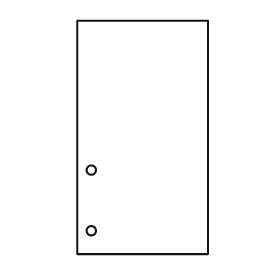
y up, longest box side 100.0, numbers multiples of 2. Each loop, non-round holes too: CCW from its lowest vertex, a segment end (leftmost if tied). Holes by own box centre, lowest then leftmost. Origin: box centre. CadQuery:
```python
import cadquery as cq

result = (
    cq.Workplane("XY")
    .moveTo(-28.0, -50.0)
    .lineTo(28.0, -50.0)
    .lineTo(28.0, 50.0)
    .lineTo(-28.0, 50.0)
    .close()
    .moveTo(-22.0, -40.0)
    .circle(2.0)
    .moveTo(-22.0, -14.0)
    .circle(2.0)
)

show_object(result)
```